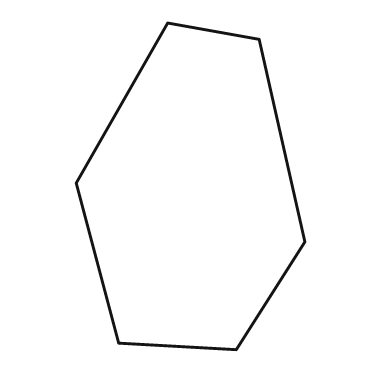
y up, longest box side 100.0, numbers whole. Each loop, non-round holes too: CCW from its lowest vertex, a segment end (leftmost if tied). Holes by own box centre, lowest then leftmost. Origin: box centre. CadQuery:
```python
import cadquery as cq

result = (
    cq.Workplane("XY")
    .moveTo(14.0, -50.0)
    .lineTo(35.0, -17.0)
    .lineTo(21.0, 45.0)
    .lineTo(-7.0, 50.0)
    .lineTo(-35.0, 1.0)
    .lineTo(-22.0, -48.0)
    .close()
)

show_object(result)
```